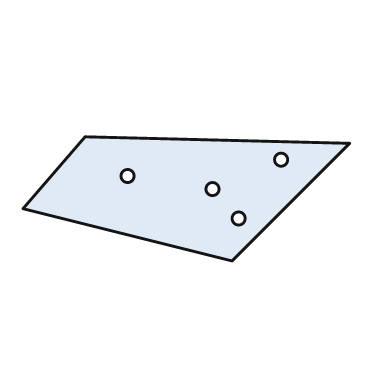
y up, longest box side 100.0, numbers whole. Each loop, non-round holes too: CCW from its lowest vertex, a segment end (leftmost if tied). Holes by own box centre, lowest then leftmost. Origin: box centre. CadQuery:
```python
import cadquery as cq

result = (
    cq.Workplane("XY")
    .moveTo(14.0, -19.0)
    .lineTo(50.0, 17.0)
    .lineTo(-31.0, 19.0)
    .lineTo(-50.0, -3.0)
    .close()
    .moveTo(16.0, -6.0)
    .circle(2.0)
    .moveTo(8.0, 3.0)
    .circle(2.0)
    .moveTo(-18.0, 7.0)
    .circle(2.0)
    .moveTo(29.0, 12.0)
    .circle(2.0)
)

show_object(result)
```